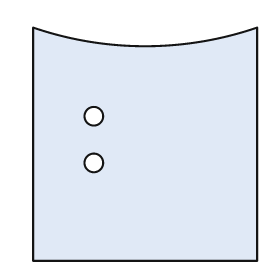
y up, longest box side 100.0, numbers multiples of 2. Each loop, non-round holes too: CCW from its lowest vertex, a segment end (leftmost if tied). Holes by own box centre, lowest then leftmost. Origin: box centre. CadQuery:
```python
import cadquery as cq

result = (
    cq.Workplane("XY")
    .moveTo(-48.0, -50.0)
    .lineTo(48.0, -50.0)
    .lineTo(48.0, 50.0)
    .threePointArc((0.0, 42.0), (-48.0, 50.0))
    .close()
    .moveTo(-22.0, -8.0)
    .circle(4.0)
    .moveTo(-22.0, 12.0)
    .circle(4.0)
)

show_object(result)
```